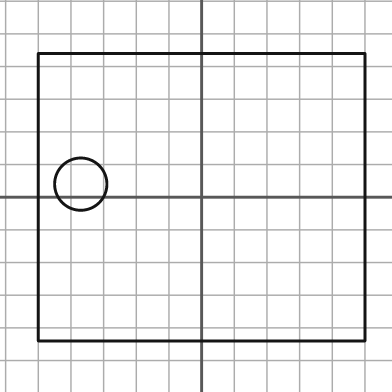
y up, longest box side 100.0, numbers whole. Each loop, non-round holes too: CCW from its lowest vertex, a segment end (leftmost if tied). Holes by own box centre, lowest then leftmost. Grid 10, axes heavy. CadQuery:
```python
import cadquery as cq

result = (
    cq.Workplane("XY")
    .moveTo(-50.0, -44.0)
    .lineTo(50.0, -44.0)
    .lineTo(50.0, 44.0)
    .lineTo(-50.0, 44.0)
    .close()
    .moveTo(-37.0, 4.0)
    .circle(8.0)
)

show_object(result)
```